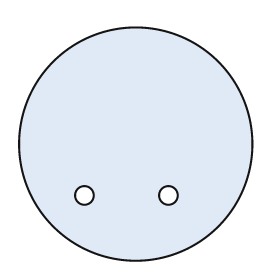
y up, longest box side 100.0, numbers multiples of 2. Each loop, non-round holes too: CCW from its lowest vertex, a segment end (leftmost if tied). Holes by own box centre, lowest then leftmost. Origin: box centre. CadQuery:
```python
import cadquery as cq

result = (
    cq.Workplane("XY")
    .moveTo(0.0, 0.0)
    .circle(50.0)
    .moveTo(-22.0, -22.0)
    .circle(4.0)
    .moveTo(14.0, -22.0)
    .circle(4.0)
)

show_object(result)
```